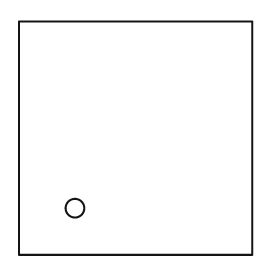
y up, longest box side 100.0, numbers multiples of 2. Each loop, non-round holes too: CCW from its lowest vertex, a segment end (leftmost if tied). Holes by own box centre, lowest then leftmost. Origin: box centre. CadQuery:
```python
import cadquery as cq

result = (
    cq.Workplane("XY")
    .moveTo(-50.0, -50.0)
    .lineTo(50.0, -50.0)
    .lineTo(50.0, 50.0)
    .lineTo(-50.0, 50.0)
    .close()
    .moveTo(-26.0, -30.0)
    .circle(4.0)
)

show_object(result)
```